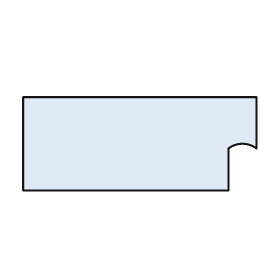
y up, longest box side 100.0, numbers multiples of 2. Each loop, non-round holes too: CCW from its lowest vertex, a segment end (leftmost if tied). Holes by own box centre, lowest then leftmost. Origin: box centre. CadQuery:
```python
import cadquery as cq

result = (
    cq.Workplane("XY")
    .moveTo(-50.0, -20.0)
    .lineTo(38.0, -20.0)
    .lineTo(38.0, -2.0)
    .threePointArc((44.0, 0.0), (50.0, -2.0))
    .lineTo(50.0, 20.0)
    .lineTo(-50.0, 20.0)
    .close()
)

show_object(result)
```